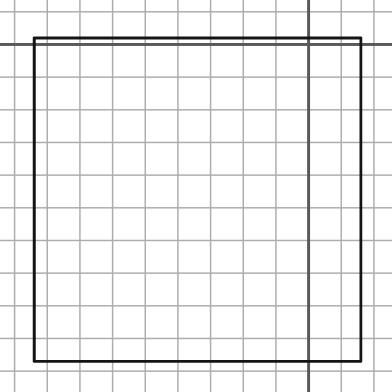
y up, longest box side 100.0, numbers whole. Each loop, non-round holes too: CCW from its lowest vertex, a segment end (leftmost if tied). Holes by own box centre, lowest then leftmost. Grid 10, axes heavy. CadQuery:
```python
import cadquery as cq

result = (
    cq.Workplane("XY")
    .moveTo(-84.0, -97.0)
    .lineTo(16.0, -97.0)
    .lineTo(16.0, 2.0)
    .lineTo(-84.0, 2.0)
    .close()
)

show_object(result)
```